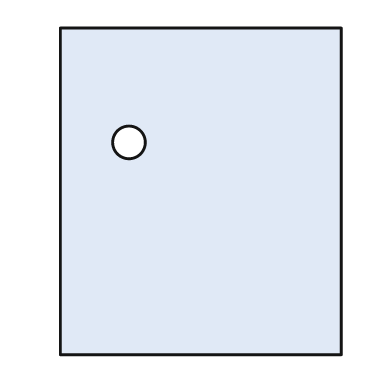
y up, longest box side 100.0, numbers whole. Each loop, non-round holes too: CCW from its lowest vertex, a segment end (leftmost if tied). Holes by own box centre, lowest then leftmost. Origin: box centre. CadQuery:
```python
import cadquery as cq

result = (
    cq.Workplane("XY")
    .moveTo(-43.0, -50.0)
    .lineTo(43.0, -50.0)
    .lineTo(43.0, 50.0)
    .lineTo(-43.0, 50.0)
    .close()
    .moveTo(-22.0, 15.0)
    .circle(5.0)
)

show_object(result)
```